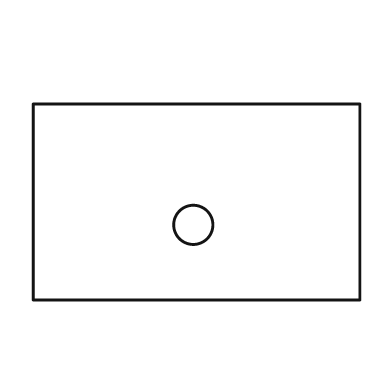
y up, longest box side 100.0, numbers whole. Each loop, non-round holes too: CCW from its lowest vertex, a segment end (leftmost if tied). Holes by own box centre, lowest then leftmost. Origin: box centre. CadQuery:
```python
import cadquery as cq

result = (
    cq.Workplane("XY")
    .moveTo(-50.0, -30.0)
    .lineTo(50.0, -30.0)
    .lineTo(50.0, 30.0)
    .lineTo(-50.0, 30.0)
    .close()
    .moveTo(-1.0, -7.0)
    .circle(6.0)
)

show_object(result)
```